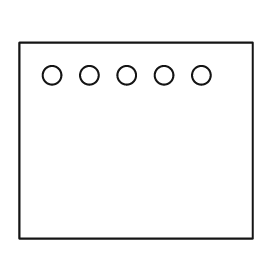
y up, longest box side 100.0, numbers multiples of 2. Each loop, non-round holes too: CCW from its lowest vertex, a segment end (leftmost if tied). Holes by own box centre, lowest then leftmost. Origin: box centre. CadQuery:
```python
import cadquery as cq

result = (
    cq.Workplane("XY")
    .moveTo(-50.0, -42.0)
    .lineTo(50.0, -42.0)
    .lineTo(50.0, 42.0)
    .lineTo(-50.0, 42.0)
    .close()
    .moveTo(-36.0, 28.0)
    .circle(4.0)
    .moveTo(-20.0, 28.0)
    .circle(4.0)
    .moveTo(-4.0, 28.0)
    .circle(4.0)
    .moveTo(12.0, 28.0)
    .circle(4.0)
    .moveTo(28.0, 28.0)
    .circle(4.0)
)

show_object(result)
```